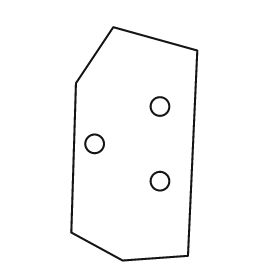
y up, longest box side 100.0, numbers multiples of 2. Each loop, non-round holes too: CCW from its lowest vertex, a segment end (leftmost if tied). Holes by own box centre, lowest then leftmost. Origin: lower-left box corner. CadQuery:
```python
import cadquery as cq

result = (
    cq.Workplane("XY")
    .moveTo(22.0, 0.0)
    .lineTo(50.0, 2.0)
    .lineTo(54.0, 90.0)
    .lineTo(18.0, 100.0)
    .lineTo(2.0, 76.0)
    .lineTo(0.0, 12.0)
    .close()
    .moveTo(38.0, 34.0)
    .circle(4.0)
    .moveTo(10.0, 50.0)
    .circle(4.0)
    .moveTo(38.0, 66.0)
    .circle(4.0)
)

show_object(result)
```